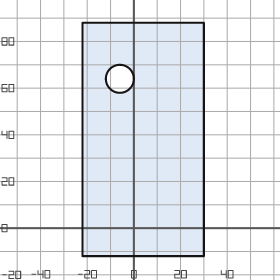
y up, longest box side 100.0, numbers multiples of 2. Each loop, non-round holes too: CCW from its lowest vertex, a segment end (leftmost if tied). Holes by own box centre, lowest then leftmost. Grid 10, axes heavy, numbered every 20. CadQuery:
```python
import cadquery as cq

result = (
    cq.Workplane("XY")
    .moveTo(-22.0, -12.0)
    .lineTo(30.0, -12.0)
    .lineTo(30.0, 88.0)
    .lineTo(-22.0, 88.0)
    .close()
    .moveTo(-6.0, 64.0)
    .circle(6.0)
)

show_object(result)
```